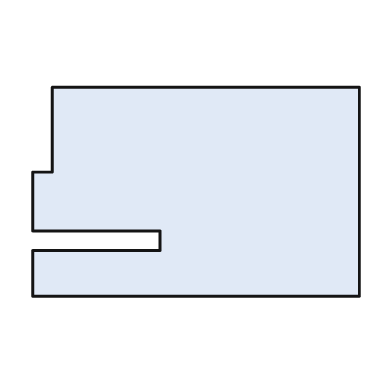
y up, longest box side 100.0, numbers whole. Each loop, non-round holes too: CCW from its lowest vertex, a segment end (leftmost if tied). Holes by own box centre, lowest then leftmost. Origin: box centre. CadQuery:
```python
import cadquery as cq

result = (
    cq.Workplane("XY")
    .moveTo(-50.0, -32.0)
    .lineTo(50.0, -32.0)
    .lineTo(50.0, 32.0)
    .lineTo(-44.0, 32.0)
    .lineTo(-44.0, 6.0)
    .lineTo(-50.0, 6.0)
    .lineTo(-50.0, -12.0)
    .lineTo(-11.0, -12.0)
    .lineTo(-11.0, -18.0)
    .lineTo(-50.0, -18.0)
    .close()
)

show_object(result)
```